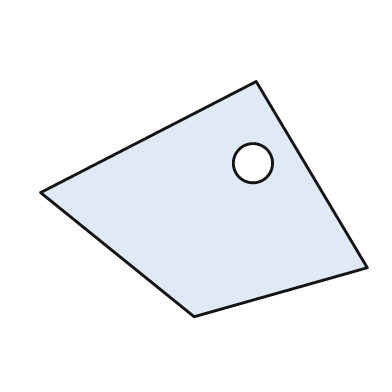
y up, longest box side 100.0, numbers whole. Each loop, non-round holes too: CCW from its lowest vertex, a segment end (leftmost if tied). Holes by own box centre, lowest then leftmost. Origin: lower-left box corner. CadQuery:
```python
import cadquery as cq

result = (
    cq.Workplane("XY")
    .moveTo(47.0, 0.0)
    .lineTo(100.0, 15.0)
    .lineTo(66.0, 72.0)
    .lineTo(0.0, 38.0)
    .close()
    .moveTo(65.0, 47.0)
    .circle(6.0)
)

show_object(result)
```